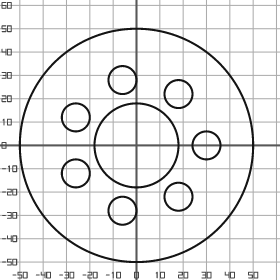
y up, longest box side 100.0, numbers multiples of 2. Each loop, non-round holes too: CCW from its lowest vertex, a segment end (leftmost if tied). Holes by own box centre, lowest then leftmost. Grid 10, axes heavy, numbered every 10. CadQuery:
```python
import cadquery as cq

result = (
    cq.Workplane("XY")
    .moveTo(0.0, 0.0)
    .circle(50.0)
    .moveTo(-6.0, -28.0)
    .circle(6.0)
    .moveTo(18.0, -22.0)
    .circle(6.0)
    .moveTo(-26.0, -12.0)
    .circle(6.0)
    .moveTo(0.0, 0.0)
    .circle(18.0)
    .moveTo(30.0, 0.0)
    .circle(6.0)
    .moveTo(-26.0, 12.0)
    .circle(6.0)
    .moveTo(18.0, 22.0)
    .circle(6.0)
    .moveTo(-6.0, 28.0)
    .circle(6.0)
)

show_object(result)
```